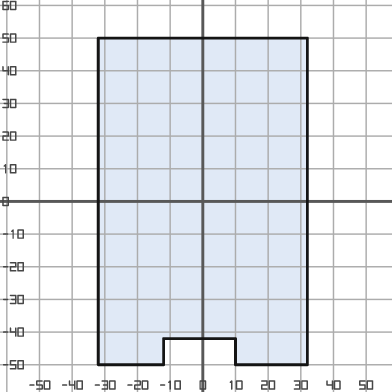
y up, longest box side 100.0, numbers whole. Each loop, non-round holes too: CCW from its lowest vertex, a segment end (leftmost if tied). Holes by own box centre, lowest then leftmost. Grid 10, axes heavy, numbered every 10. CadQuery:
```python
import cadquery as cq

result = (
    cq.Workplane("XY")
    .moveTo(-32.0, -50.0)
    .lineTo(-12.0, -50.0)
    .lineTo(-12.0, -42.0)
    .lineTo(10.0, -42.0)
    .lineTo(10.0, -50.0)
    .lineTo(32.0, -50.0)
    .lineTo(32.0, 50.0)
    .lineTo(-32.0, 50.0)
    .close()
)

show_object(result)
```